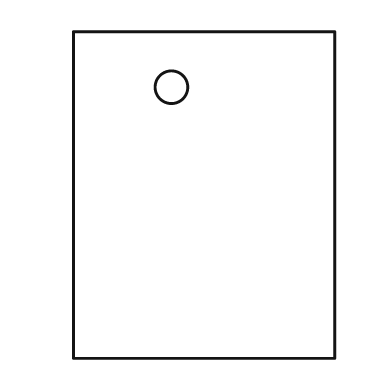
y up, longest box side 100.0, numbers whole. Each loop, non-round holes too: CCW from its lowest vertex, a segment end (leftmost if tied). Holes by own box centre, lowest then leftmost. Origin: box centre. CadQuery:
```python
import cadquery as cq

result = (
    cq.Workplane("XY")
    .moveTo(-40.0, -50.0)
    .lineTo(40.0, -50.0)
    .lineTo(40.0, 50.0)
    .lineTo(-40.0, 50.0)
    .close()
    .moveTo(-10.0, 33.0)
    .circle(5.0)
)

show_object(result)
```